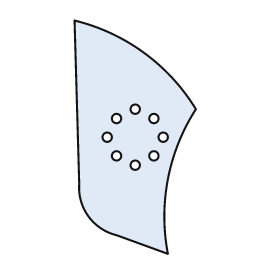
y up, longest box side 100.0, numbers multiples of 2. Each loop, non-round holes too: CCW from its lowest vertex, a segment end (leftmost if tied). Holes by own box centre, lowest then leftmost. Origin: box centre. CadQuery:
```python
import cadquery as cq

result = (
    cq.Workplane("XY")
    .moveTo(14.0, -50.0)
    .threePointArc((14.0, -18.0), (26.0, 12.0))
    .threePointArc((4.0, 36.0), (-26.0, 50.0))
    .lineTo(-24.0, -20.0)
    .threePointArc((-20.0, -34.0), (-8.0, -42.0))
    .close()
    .moveTo(0.0, -12.0)
    .circle(2.0)
    .moveTo(-8.0, -8.0)
    .circle(2.0)
    .moveTo(8.0, -8.0)
    .circle(2.0)
    .moveTo(-12.0, 0.0)
    .circle(2.0)
    .moveTo(12.0, 0.0)
    .circle(2.0)
    .moveTo(-8.0, 8.0)
    .circle(2.0)
    .moveTo(8.0, 8.0)
    .circle(2.0)
    .moveTo(0.0, 12.0)
    .circle(2.0)
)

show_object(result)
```